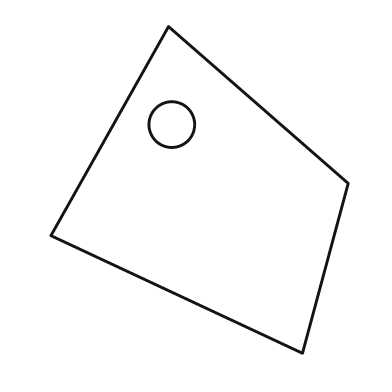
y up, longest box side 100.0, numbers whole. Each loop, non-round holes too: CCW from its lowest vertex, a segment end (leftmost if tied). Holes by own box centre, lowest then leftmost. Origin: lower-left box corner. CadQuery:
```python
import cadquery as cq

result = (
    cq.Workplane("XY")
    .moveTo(77.0, 0.0)
    .lineTo(91.0, 52.0)
    .lineTo(36.0, 100.0)
    .lineTo(0.0, 36.0)
    .close()
    .moveTo(37.0, 70.0)
    .circle(7.0)
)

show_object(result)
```